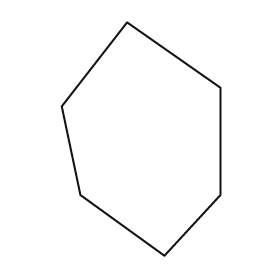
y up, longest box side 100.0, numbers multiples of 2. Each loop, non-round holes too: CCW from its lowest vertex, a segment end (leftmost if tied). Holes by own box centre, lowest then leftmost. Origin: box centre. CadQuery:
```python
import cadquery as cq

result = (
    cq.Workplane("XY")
    .moveTo(10.0, -50.0)
    .lineTo(34.0, -24.0)
    .lineTo(34.0, 22.0)
    .lineTo(-6.0, 50.0)
    .lineTo(-34.0, 14.0)
    .lineTo(-26.0, -24.0)
    .close()
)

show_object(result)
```